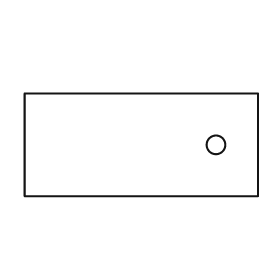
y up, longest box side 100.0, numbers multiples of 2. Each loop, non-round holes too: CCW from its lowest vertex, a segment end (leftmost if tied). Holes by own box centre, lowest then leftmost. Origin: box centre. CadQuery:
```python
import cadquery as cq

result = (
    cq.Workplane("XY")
    .moveTo(-50.0, -22.0)
    .lineTo(50.0, -22.0)
    .lineTo(50.0, 22.0)
    .lineTo(-50.0, 22.0)
    .close()
    .moveTo(32.0, 0.0)
    .circle(4.0)
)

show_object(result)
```